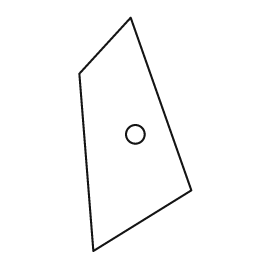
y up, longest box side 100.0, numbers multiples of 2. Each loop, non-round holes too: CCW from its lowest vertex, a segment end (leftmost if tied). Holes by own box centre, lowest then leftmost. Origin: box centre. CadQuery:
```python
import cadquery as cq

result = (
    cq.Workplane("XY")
    .moveTo(-18.0, -50.0)
    .lineTo(24.0, -24.0)
    .lineTo(-2.0, 50.0)
    .lineTo(-24.0, 26.0)
    .close()
    .moveTo(0.0, 0.0)
    .circle(4.0)
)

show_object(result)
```